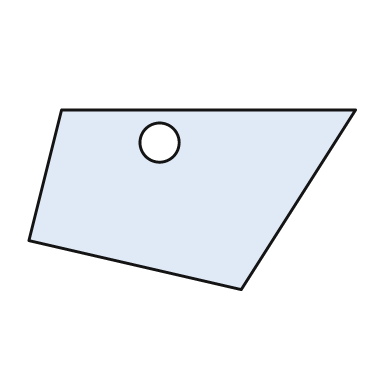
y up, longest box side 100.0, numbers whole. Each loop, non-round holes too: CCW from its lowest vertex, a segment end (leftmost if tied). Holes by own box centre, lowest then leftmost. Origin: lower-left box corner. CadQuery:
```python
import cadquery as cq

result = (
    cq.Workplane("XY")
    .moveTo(65.0, 0.0)
    .lineTo(100.0, 55.0)
    .lineTo(10.0, 55.0)
    .lineTo(0.0, 15.0)
    .close()
    .moveTo(40.0, 45.0)
    .circle(6.0)
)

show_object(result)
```